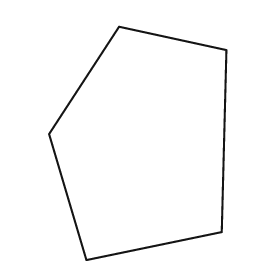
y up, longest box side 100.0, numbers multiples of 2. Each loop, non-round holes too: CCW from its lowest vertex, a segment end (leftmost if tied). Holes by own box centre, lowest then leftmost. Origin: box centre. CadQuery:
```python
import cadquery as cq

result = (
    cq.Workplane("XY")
    .moveTo(-22.0, -50.0)
    .lineTo(36.0, -38.0)
    .lineTo(38.0, 40.0)
    .lineTo(-8.0, 50.0)
    .lineTo(-38.0, 4.0)
    .close()
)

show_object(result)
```